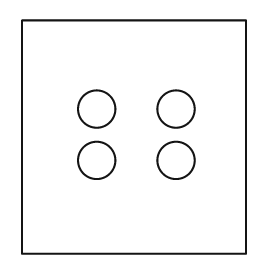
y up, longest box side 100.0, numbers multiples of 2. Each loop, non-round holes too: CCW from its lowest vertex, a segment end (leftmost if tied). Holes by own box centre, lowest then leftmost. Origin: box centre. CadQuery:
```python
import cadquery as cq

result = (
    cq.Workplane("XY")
    .moveTo(-48.0, -50.0)
    .lineTo(48.0, -50.0)
    .lineTo(48.0, 50.0)
    .lineTo(-48.0, 50.0)
    .close()
    .moveTo(-16.0, -10.0)
    .circle(8.0)
    .moveTo(18.0, -10.0)
    .circle(8.0)
    .moveTo(-16.0, 12.0)
    .circle(8.0)
    .moveTo(18.0, 12.0)
    .circle(8.0)
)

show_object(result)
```